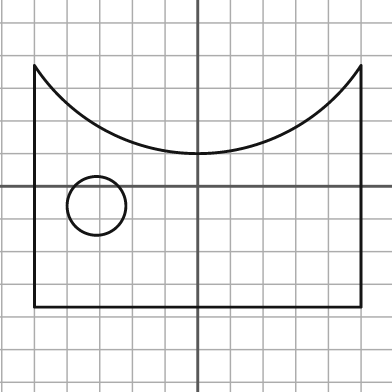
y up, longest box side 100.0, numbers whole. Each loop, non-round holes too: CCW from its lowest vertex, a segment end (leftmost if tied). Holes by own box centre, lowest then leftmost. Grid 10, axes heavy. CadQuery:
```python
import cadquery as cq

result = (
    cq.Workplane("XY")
    .moveTo(-50.0, -37.0)
    .lineTo(50.0, -37.0)
    .lineTo(50.0, 37.0)
    .threePointArc((0.0, 10.0), (-50.0, 37.0))
    .close()
    .moveTo(-31.0, -6.0)
    .circle(9.0)
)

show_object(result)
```